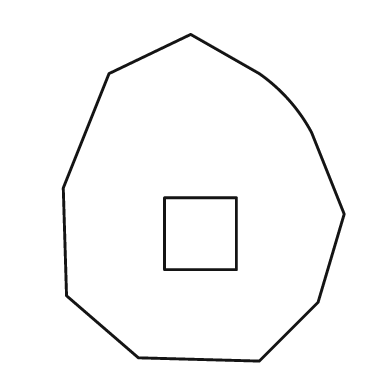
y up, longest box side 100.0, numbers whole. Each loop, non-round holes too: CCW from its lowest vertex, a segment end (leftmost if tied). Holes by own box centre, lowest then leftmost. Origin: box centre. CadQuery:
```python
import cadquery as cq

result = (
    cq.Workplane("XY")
    .moveTo(17.0, -50.0)
    .lineTo(35.0, -32.0)
    .lineTo(43.0, -5.0)
    .lineTo(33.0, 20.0)
    .threePointArc((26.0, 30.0), (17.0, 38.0))
    .lineTo(-4.0, 50.0)
    .lineTo(-29.0, 38.0)
    .lineTo(-43.0, 3.0)
    .lineTo(-42.0, -30.0)
    .lineTo(-20.0, -49.0)
    .close()
    .moveTo(-12.0, -22.0)
    .lineTo(10.0, -22.0)
    .lineTo(10.0, 0.0)
    .lineTo(-12.0, 0.0)
    .close()
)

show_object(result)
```